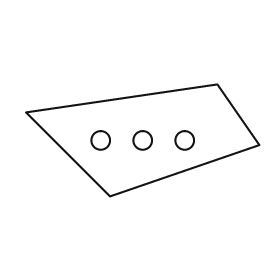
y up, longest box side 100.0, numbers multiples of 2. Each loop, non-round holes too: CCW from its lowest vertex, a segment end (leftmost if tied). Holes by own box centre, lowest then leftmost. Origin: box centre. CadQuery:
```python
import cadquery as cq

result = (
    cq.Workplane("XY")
    .moveTo(-14.0, -24.0)
    .lineTo(50.0, -2.0)
    .lineTo(32.0, 24.0)
    .lineTo(-50.0, 12.0)
    .close()
    .moveTo(-18.0, 0.0)
    .circle(4.0)
    .moveTo(0.0, 0.0)
    .circle(4.0)
    .moveTo(18.0, 0.0)
    .circle(4.0)
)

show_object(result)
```